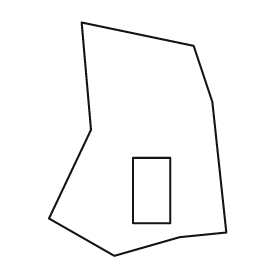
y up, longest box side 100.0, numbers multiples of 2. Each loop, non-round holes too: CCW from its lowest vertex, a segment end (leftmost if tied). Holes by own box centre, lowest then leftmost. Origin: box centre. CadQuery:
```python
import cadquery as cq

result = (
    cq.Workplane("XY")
    .moveTo(-10.0, -50.0)
    .lineTo(18.0, -42.0)
    .lineTo(38.0, -40.0)
    .lineTo(32.0, 16.0)
    .lineTo(24.0, 40.0)
    .lineTo(-24.0, 50.0)
    .lineTo(-20.0, 4.0)
    .lineTo(-38.0, -34.0)
    .close()
    .moveTo(-2.0, -36.0)
    .lineTo(14.0, -36.0)
    .lineTo(14.0, -8.0)
    .lineTo(-2.0, -8.0)
    .close()
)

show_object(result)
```